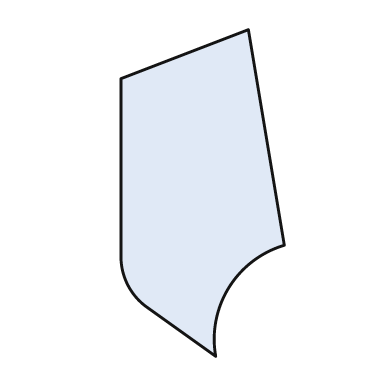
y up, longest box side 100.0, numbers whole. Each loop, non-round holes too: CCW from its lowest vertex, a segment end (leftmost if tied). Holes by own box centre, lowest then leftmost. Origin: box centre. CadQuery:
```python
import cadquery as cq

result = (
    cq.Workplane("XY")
    .moveTo(4.0, -50.0)
    .threePointArc((8.0, -29.0), (25.0, -16.0))
    .lineTo(14.0, 50.0)
    .lineTo(-25.0, 35.0)
    .lineTo(-25.0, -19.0)
    .threePointArc((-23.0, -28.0), (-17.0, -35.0))
    .close()
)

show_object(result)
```